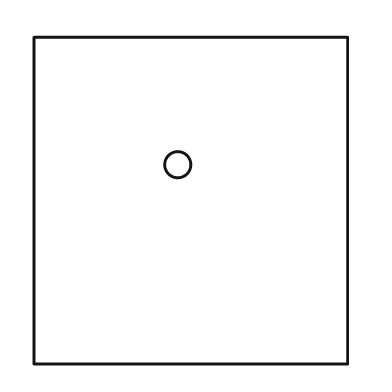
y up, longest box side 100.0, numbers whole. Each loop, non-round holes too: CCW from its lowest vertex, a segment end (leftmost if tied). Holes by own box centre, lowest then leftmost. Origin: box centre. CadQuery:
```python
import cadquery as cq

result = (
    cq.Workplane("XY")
    .moveTo(-48.0, -50.0)
    .lineTo(48.0, -50.0)
    .lineTo(48.0, 50.0)
    .lineTo(-48.0, 50.0)
    .close()
    .moveTo(-4.0, 11.0)
    .circle(4.0)
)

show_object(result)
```